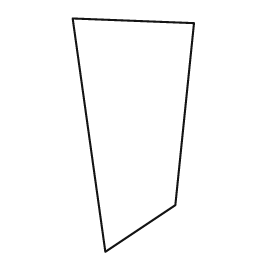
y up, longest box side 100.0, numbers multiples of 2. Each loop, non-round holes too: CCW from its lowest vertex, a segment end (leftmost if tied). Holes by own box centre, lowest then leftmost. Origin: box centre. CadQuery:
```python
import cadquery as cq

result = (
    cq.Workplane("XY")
    .moveTo(-12.0, -50.0)
    .lineTo(18.0, -30.0)
    .lineTo(26.0, 48.0)
    .lineTo(-26.0, 50.0)
    .close()
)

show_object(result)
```